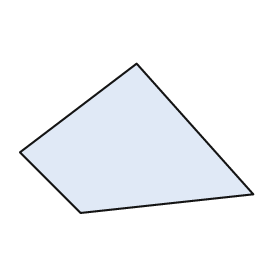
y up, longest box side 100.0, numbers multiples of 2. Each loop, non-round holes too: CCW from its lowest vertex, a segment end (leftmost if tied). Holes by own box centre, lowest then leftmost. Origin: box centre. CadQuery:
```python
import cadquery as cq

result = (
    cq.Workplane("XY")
    .moveTo(-24.0, -32.0)
    .lineTo(50.0, -24.0)
    .lineTo(0.0, 32.0)
    .lineTo(-50.0, -6.0)
    .close()
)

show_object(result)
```